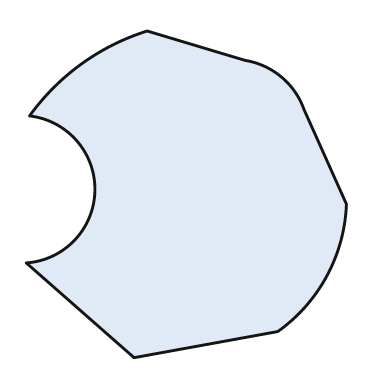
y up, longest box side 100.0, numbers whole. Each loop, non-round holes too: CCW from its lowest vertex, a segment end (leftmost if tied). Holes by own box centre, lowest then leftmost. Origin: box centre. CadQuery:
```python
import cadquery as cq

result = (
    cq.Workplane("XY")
    .moveTo(-16.0, -50.0)
    .lineTo(28.0, -42.0)
    .threePointArc((43.0, -25.0), (49.0, -3.0))
    .lineTo(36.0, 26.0)
    .threePointArc((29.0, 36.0), (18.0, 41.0))
    .lineTo(-12.0, 50.0)
    .threePointArc((-32.0, 40.0), (-48.0, 24.0))
    .threePointArc((-28.0, 1.0), (-49.0, -21.0))
    .close()
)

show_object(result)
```